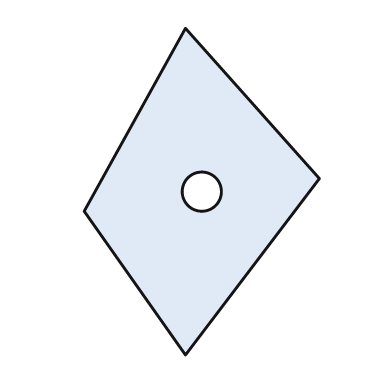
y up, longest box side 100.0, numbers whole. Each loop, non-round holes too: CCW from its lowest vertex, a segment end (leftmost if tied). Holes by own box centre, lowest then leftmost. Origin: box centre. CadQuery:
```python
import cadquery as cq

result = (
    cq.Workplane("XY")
    .moveTo(-5.0, -50.0)
    .lineTo(36.0, 4.0)
    .lineTo(-5.0, 50.0)
    .lineTo(-36.0, -6.0)
    .close()
    .moveTo(0.0, 0.0)
    .circle(6.0)
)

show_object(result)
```